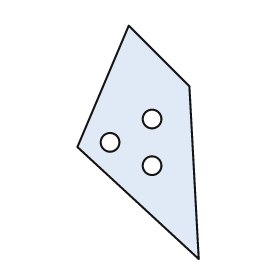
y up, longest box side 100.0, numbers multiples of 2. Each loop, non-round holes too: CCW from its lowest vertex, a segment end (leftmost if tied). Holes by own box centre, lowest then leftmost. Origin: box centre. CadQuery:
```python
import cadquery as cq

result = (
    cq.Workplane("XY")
    .moveTo(26.0, -50.0)
    .lineTo(22.0, 24.0)
    .lineTo(-4.0, 50.0)
    .lineTo(-26.0, -2.0)
    .close()
    .moveTo(6.0, -10.0)
    .circle(4.0)
    .moveTo(-12.0, 0.0)
    .circle(4.0)
    .moveTo(6.0, 10.0)
    .circle(4.0)
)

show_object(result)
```